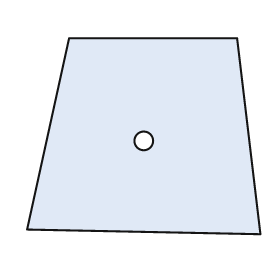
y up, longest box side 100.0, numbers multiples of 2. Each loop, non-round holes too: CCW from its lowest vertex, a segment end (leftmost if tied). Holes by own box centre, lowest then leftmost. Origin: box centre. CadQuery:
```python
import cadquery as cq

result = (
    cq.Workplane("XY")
    .moveTo(50.0, -42.0)
    .lineTo(40.0, 42.0)
    .lineTo(-32.0, 42.0)
    .lineTo(-50.0, -40.0)
    .close()
    .moveTo(0.0, -2.0)
    .circle(4.0)
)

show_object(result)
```